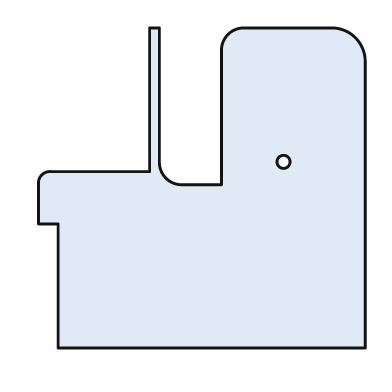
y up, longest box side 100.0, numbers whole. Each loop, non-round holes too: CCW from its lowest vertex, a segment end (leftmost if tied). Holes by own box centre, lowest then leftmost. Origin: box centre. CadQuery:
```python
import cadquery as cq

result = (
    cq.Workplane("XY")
    .moveTo(-44.0, -49.0)
    .lineTo(50.0, -49.0)
    .lineTo(50.0, 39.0)
    .threePointArc((47.0, 46.0), (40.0, 49.0))
    .lineTo(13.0, 49.0)
    .threePointArc((8.0, 47.0), (6.0, 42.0))
    .lineTo(6.0, 1.0)
    .lineTo(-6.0, 1.0)
    .threePointArc((-11.0, 3.0), (-13.0, 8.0))
    .lineTo(-13.0, 49.0)
    .lineTo(-16.0, 49.0)
    .lineTo(-16.0, 5.0)
    .lineTo(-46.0, 5.0)
    .threePointArc((-49.0, 4.0), (-50.0, 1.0))
    .lineTo(-50.0, -11.0)
    .lineTo(-44.0, -11.0)
    .close()
    .moveTo(25.0, 8.0)
    .circle(2.0)
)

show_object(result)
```